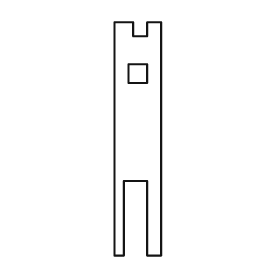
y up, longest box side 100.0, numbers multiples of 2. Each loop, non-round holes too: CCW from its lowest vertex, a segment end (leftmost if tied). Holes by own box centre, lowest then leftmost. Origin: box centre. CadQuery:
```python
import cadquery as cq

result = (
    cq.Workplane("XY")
    .moveTo(-10.0, -50.0)
    .lineTo(-6.0, -50.0)
    .lineTo(-6.0, -18.0)
    .lineTo(4.0, -18.0)
    .lineTo(4.0, -50.0)
    .lineTo(10.0, -50.0)
    .lineTo(10.0, 50.0)
    .lineTo(4.0, 50.0)
    .lineTo(4.0, 44.0)
    .lineTo(-2.0, 44.0)
    .lineTo(-2.0, 50.0)
    .lineTo(-10.0, 50.0)
    .close()
    .moveTo(-4.0, 24.0)
    .lineTo(4.0, 24.0)
    .lineTo(4.0, 32.0)
    .lineTo(-4.0, 32.0)
    .close()
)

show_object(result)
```